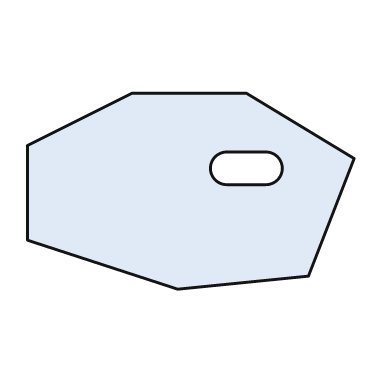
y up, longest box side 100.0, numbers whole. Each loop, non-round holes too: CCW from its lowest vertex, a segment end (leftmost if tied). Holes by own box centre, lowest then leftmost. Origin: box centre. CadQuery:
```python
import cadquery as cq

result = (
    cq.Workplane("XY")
    .moveTo(-4.0, -30.0)
    .lineTo(36.0, -26.0)
    .lineTo(50.0, 10.0)
    .lineTo(17.0, 30.0)
    .lineTo(-18.0, 30.0)
    .lineTo(-50.0, 14.0)
    .lineTo(-50.0, -15.0)
    .close()
    .moveTo(11.0, 2.0)
    .lineTo(23.0, 2.0)
    .threePointArc((28.0, 7.0), (23.0, 12.0))
    .lineTo(11.0, 12.0)
    .threePointArc((6.0, 7.0), (11.0, 2.0))
    .close()
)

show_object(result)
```